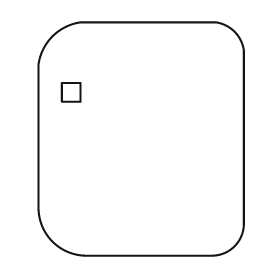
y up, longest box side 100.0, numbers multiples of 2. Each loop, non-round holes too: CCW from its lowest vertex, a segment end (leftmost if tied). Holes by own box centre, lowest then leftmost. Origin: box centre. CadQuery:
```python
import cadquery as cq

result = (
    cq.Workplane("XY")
    .moveTo(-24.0, -50.0)
    .lineTo(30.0, -50.0)
    .threePointArc((40.0, -46.0), (44.0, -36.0))
    .lineTo(44.0, 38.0)
    .threePointArc((40.0, 46.0), (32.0, 50.0))
    .lineTo(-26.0, 50.0)
    .threePointArc((-38.0, 44.0), (-44.0, 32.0))
    .lineTo(-44.0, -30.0)
    .threePointArc((-38.0, -44.0), (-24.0, -50.0))
    .close()
    .moveTo(-34.0, 16.0)
    .lineTo(-26.0, 16.0)
    .lineTo(-26.0, 24.0)
    .lineTo(-34.0, 24.0)
    .close()
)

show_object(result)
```